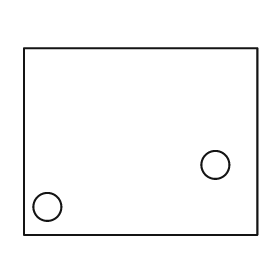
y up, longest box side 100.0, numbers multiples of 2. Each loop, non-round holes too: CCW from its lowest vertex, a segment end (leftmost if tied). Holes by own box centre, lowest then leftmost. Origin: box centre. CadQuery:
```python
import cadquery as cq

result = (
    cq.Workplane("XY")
    .moveTo(-50.0, -40.0)
    .lineTo(50.0, -40.0)
    .lineTo(50.0, 40.0)
    .lineTo(-50.0, 40.0)
    .close()
    .moveTo(-40.0, -28.0)
    .circle(6.0)
    .moveTo(32.0, -10.0)
    .circle(6.0)
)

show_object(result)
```